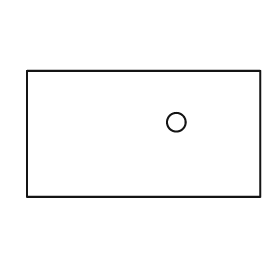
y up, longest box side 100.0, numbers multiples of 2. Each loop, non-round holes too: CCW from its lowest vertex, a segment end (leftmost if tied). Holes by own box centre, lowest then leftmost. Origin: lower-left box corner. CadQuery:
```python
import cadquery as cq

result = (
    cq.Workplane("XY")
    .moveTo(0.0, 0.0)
    .lineTo(100.0, 0.0)
    .lineTo(100.0, 54.0)
    .lineTo(0.0, 54.0)
    .close()
    .moveTo(64.0, 32.0)
    .circle(4.0)
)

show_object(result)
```